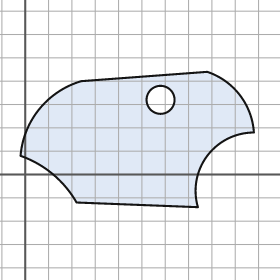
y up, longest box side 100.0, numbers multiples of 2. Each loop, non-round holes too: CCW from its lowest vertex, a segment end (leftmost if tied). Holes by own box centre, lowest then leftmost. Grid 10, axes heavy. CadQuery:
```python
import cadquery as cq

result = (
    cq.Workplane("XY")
    .moveTo(74.0, -14.0)
    .threePointArc((78.0, 8.0), (98.0, 18.0))
    .threePointArc((92.0, 34.0), (78.0, 44.0))
    .lineTo(24.0, 40.0)
    .threePointArc((6.0, 28.0), (-2.0, 8.0))
    .threePointArc((12.0, 0.0), (22.0, -12.0))
    .close()
    .moveTo(58.0, 32.0)
    .circle(6.0)
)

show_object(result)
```